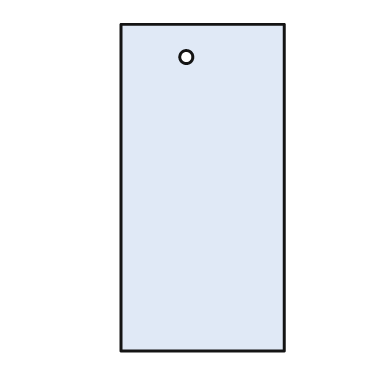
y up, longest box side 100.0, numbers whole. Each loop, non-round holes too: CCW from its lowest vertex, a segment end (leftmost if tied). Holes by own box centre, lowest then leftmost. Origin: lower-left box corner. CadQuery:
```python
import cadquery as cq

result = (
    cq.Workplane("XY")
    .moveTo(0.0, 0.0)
    .lineTo(50.0, 0.0)
    .lineTo(50.0, 100.0)
    .lineTo(0.0, 100.0)
    .close()
    .moveTo(20.0, 90.0)
    .circle(2.0)
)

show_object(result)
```